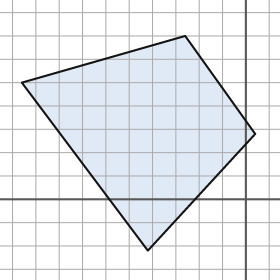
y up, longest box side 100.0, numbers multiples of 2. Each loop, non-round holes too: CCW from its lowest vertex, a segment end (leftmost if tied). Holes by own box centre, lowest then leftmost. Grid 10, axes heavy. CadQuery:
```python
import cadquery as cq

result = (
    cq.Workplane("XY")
    .moveTo(-42.0, -22.0)
    .lineTo(4.0, 28.0)
    .lineTo(-26.0, 70.0)
    .lineTo(-96.0, 50.0)
    .close()
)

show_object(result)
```